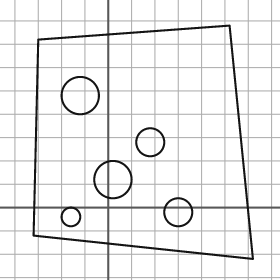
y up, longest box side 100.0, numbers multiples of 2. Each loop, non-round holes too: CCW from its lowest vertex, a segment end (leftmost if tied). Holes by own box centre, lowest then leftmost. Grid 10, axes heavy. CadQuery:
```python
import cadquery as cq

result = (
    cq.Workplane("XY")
    .moveTo(62.0, -22.0)
    .lineTo(52.0, 78.0)
    .lineTo(-30.0, 72.0)
    .lineTo(-32.0, -12.0)
    .close()
    .moveTo(-16.0, -4.0)
    .circle(4.0)
    .moveTo(30.0, -2.0)
    .circle(6.0)
    .moveTo(2.0, 12.0)
    .circle(8.0)
    .moveTo(18.0, 28.0)
    .circle(6.0)
    .moveTo(-12.0, 48.0)
    .circle(8.0)
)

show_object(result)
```